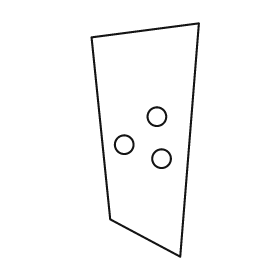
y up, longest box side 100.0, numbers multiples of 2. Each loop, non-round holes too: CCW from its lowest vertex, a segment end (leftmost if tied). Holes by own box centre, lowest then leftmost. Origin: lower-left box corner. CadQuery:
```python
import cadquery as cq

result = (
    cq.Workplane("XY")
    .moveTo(38.0, 0.0)
    .lineTo(46.0, 100.0)
    .lineTo(0.0, 94.0)
    .lineTo(8.0, 16.0)
    .close()
    .moveTo(30.0, 42.0)
    .circle(4.0)
    .moveTo(14.0, 48.0)
    .circle(4.0)
    .moveTo(28.0, 60.0)
    .circle(4.0)
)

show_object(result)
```